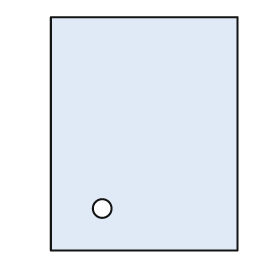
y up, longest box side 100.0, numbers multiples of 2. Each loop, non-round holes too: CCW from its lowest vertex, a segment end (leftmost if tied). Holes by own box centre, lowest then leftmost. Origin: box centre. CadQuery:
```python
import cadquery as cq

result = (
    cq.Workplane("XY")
    .moveTo(-40.0, -50.0)
    .lineTo(40.0, -50.0)
    .lineTo(40.0, 50.0)
    .lineTo(-40.0, 50.0)
    .close()
    .moveTo(-18.0, -32.0)
    .circle(4.0)
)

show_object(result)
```